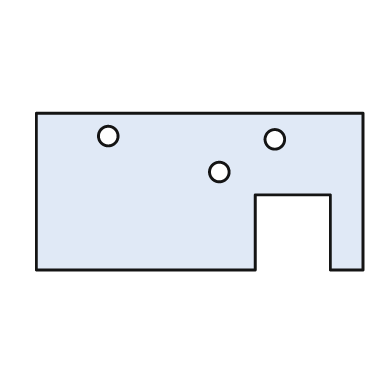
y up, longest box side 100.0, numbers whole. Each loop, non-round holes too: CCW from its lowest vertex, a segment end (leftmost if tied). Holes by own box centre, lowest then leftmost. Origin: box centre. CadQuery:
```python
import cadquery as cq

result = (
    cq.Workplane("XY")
    .moveTo(-50.0, -24.0)
    .lineTo(17.0, -24.0)
    .lineTo(17.0, -1.0)
    .lineTo(40.0, -1.0)
    .lineTo(40.0, -24.0)
    .lineTo(50.0, -24.0)
    .lineTo(50.0, 24.0)
    .lineTo(-50.0, 24.0)
    .close()
    .moveTo(6.0, 6.0)
    .circle(3.0)
    .moveTo(23.0, 16.0)
    .circle(3.0)
    .moveTo(-28.0, 17.0)
    .circle(3.0)
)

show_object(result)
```